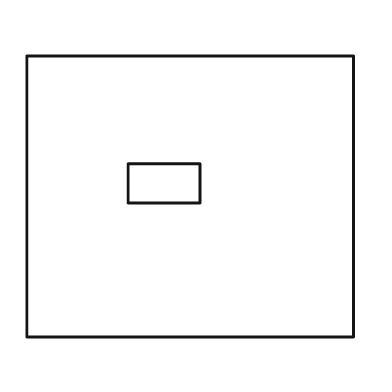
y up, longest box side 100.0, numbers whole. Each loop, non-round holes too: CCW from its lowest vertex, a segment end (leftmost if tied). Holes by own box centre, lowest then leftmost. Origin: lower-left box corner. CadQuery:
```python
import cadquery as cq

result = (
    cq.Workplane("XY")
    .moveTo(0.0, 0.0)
    .lineTo(100.0, 0.0)
    .lineTo(100.0, 86.0)
    .lineTo(0.0, 86.0)
    .close()
    .moveTo(31.0, 41.0)
    .lineTo(53.0, 41.0)
    .lineTo(53.0, 53.0)
    .lineTo(31.0, 53.0)
    .close()
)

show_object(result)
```